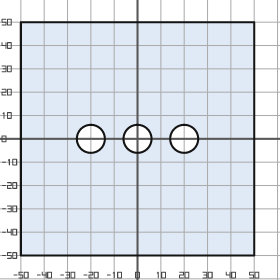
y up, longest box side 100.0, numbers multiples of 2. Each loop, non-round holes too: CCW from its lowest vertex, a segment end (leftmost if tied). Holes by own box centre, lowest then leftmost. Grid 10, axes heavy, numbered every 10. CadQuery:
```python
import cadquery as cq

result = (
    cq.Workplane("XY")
    .moveTo(-50.0, -50.0)
    .lineTo(50.0, -50.0)
    .lineTo(50.0, 50.0)
    .lineTo(-50.0, 50.0)
    .close()
    .moveTo(-20.0, 0.0)
    .circle(6.0)
    .moveTo(0.0, 0.0)
    .circle(6.0)
    .moveTo(20.0, 0.0)
    .circle(6.0)
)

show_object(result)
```